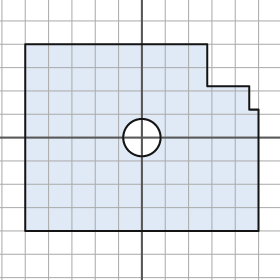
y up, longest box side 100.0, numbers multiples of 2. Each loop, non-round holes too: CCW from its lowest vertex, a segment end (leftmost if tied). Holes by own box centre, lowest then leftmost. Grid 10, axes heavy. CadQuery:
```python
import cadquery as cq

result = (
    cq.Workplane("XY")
    .moveTo(-50.0, -40.0)
    .lineTo(50.0, -40.0)
    .lineTo(50.0, 12.0)
    .lineTo(46.0, 12.0)
    .lineTo(46.0, 22.0)
    .lineTo(28.0, 22.0)
    .lineTo(28.0, 40.0)
    .lineTo(-50.0, 40.0)
    .close()
    .moveTo(0.0, 0.0)
    .circle(8.0)
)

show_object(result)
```